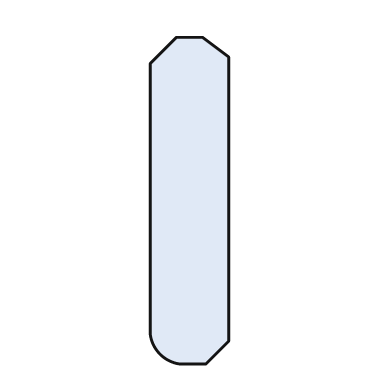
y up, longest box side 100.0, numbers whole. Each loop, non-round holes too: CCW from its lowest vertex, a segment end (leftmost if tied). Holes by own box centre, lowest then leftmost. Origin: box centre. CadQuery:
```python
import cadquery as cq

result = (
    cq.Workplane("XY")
    .moveTo(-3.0, -50.0)
    .lineTo(5.0, -50.0)
    .lineTo(12.0, -43.0)
    .lineTo(12.0, 44.0)
    .lineTo(4.0, 50.0)
    .lineTo(-4.0, 50.0)
    .lineTo(-12.0, 42.0)
    .lineTo(-12.0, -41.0)
    .threePointArc((-9.0, -47.0), (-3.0, -50.0))
    .close()
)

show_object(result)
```